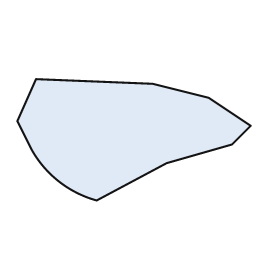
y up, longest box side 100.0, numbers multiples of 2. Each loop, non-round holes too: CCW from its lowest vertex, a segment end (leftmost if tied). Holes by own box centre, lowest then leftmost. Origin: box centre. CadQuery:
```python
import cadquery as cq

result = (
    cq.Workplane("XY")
    .moveTo(-16.0, -26.0)
    .lineTo(14.0, -10.0)
    .lineTo(42.0, -2.0)
    .lineTo(50.0, 6.0)
    .lineTo(32.0, 18.0)
    .lineTo(8.0, 24.0)
    .lineTo(-42.0, 26.0)
    .lineTo(-50.0, 8.0)
    .lineTo(-44.0, -4.0)
    .threePointArc((-32.0, -18.0), (-16.0, -26.0))
    .close()
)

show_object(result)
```